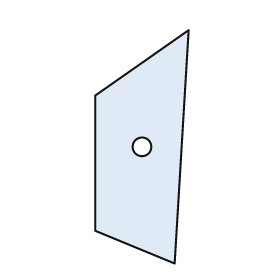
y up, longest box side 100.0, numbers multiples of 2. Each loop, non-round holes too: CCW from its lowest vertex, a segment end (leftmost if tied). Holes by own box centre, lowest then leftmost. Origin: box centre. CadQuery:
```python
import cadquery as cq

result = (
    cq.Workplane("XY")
    .moveTo(14.0, -50.0)
    .lineTo(20.0, 50.0)
    .lineTo(-20.0, 22.0)
    .lineTo(-20.0, -36.0)
    .close()
    .moveTo(0.0, 0.0)
    .circle(4.0)
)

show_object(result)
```